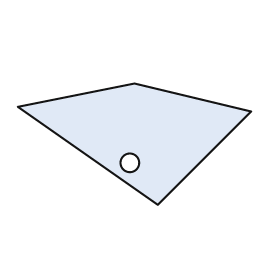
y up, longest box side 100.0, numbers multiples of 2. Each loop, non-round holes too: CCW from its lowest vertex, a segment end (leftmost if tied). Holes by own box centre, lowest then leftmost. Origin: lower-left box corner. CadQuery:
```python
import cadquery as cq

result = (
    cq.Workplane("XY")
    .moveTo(60.0, 0.0)
    .lineTo(100.0, 40.0)
    .lineTo(50.0, 52.0)
    .lineTo(0.0, 42.0)
    .close()
    .moveTo(48.0, 18.0)
    .circle(4.0)
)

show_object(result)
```